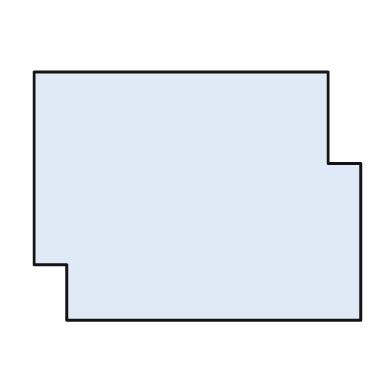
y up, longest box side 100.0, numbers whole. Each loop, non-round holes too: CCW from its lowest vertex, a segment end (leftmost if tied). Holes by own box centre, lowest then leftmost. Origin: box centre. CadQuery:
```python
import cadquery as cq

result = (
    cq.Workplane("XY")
    .moveTo(-40.0, -38.0)
    .lineTo(50.0, -38.0)
    .lineTo(50.0, 10.0)
    .lineTo(40.0, 10.0)
    .lineTo(40.0, 38.0)
    .lineTo(-50.0, 38.0)
    .lineTo(-50.0, -21.0)
    .lineTo(-40.0, -21.0)
    .close()
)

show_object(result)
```